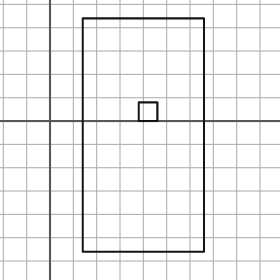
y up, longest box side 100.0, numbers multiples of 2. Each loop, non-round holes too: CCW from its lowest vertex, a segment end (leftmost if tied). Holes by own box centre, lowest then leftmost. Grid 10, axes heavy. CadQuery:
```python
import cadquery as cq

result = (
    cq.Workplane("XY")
    .moveTo(14.0, -56.0)
    .lineTo(66.0, -56.0)
    .lineTo(66.0, 44.0)
    .lineTo(14.0, 44.0)
    .close()
    .moveTo(38.0, 0.0)
    .lineTo(46.0, 0.0)
    .lineTo(46.0, 8.0)
    .lineTo(38.0, 8.0)
    .close()
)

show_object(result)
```